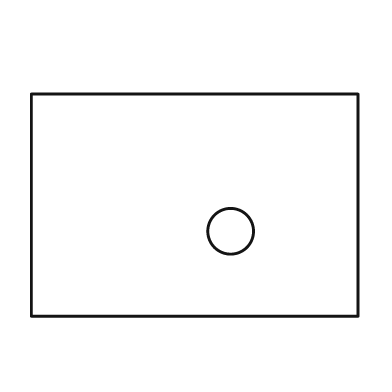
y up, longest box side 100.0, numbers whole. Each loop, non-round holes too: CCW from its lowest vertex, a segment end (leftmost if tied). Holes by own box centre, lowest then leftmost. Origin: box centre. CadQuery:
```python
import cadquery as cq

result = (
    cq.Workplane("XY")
    .moveTo(-50.0, -34.0)
    .lineTo(50.0, -34.0)
    .lineTo(50.0, 34.0)
    .lineTo(-50.0, 34.0)
    .close()
    .moveTo(11.0, -8.0)
    .circle(7.0)
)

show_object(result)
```